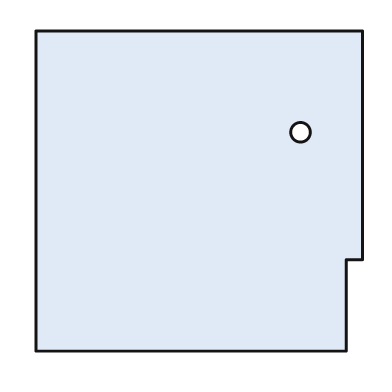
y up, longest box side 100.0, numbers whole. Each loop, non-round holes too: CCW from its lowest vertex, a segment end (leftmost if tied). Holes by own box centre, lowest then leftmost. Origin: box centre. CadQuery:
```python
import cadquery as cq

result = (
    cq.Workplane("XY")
    .moveTo(-50.0, -49.0)
    .lineTo(45.0, -49.0)
    .lineTo(45.0, -21.0)
    .lineTo(50.0, -21.0)
    .lineTo(50.0, 49.0)
    .lineTo(-50.0, 49.0)
    .close()
    .moveTo(31.0, 18.0)
    .circle(3.0)
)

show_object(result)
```